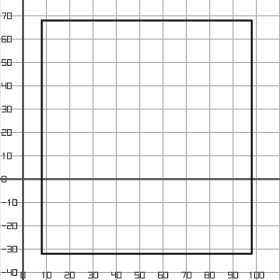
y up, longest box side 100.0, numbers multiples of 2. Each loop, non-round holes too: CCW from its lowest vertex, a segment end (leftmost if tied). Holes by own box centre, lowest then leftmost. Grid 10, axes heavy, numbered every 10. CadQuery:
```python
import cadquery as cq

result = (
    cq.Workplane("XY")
    .moveTo(8.0, -32.0)
    .lineTo(98.0, -32.0)
    .lineTo(98.0, 68.0)
    .lineTo(8.0, 68.0)
    .close()
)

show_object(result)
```